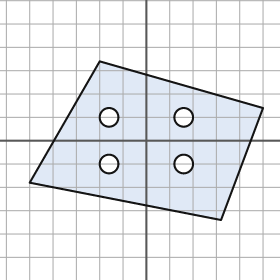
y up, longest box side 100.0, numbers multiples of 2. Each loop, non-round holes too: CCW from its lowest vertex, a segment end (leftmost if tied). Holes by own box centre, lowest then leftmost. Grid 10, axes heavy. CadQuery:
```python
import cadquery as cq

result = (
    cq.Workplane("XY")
    .moveTo(32.0, -34.0)
    .lineTo(50.0, 14.0)
    .lineTo(-20.0, 34.0)
    .lineTo(-50.0, -18.0)
    .close()
    .moveTo(-16.0, -10.0)
    .circle(4.0)
    .moveTo(16.0, -10.0)
    .circle(4.0)
    .moveTo(-16.0, 10.0)
    .circle(4.0)
    .moveTo(16.0, 10.0)
    .circle(4.0)
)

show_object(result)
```